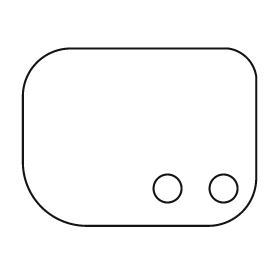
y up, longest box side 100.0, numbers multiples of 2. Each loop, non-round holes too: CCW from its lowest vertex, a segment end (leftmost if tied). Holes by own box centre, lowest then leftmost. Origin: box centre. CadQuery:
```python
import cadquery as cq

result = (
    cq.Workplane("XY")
    .moveTo(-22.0, -38.0)
    .lineTo(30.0, -38.0)
    .threePointArc((44.0, -32.0), (50.0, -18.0))
    .lineTo(50.0, 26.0)
    .threePointArc((46.0, 34.0), (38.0, 38.0))
    .lineTo(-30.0, 38.0)
    .threePointArc((-44.0, 32.0), (-50.0, 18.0))
    .lineTo(-50.0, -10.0)
    .threePointArc((-42.0, -30.0), (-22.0, -38.0))
    .close()
    .moveTo(12.0, -22.0)
    .circle(6.0)
    .moveTo(36.0, -22.0)
    .circle(6.0)
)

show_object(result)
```